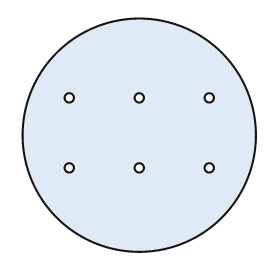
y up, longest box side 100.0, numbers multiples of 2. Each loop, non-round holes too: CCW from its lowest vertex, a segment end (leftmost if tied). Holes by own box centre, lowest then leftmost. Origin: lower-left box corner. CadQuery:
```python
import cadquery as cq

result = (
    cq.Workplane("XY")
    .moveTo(50.0, 50.0)
    .circle(50.0)
    .moveTo(20.0, 36.0)
    .circle(2.0)
    .moveTo(50.0, 36.0)
    .circle(2.0)
    .moveTo(80.0, 36.0)
    .circle(2.0)
    .moveTo(20.0, 66.0)
    .circle(2.0)
    .moveTo(50.0, 66.0)
    .circle(2.0)
    .moveTo(80.0, 66.0)
    .circle(2.0)
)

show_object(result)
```